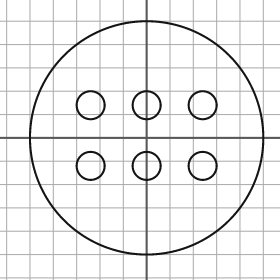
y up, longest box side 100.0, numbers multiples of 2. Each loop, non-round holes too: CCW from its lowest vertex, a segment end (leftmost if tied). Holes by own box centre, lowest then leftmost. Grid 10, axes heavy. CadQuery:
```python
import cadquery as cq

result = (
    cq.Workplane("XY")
    .moveTo(0.0, 0.0)
    .circle(50.0)
    .moveTo(-24.0, -12.0)
    .circle(6.0)
    .moveTo(0.0, -12.0)
    .circle(6.0)
    .moveTo(24.0, -12.0)
    .circle(6.0)
    .moveTo(-24.0, 14.0)
    .circle(6.0)
    .moveTo(0.0, 14.0)
    .circle(6.0)
    .moveTo(24.0, 14.0)
    .circle(6.0)
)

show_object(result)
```